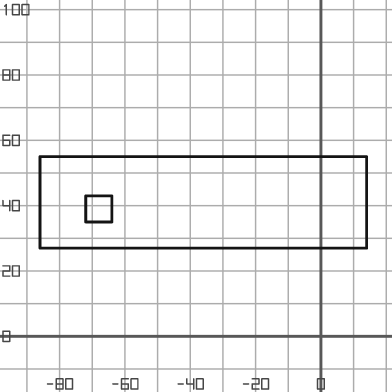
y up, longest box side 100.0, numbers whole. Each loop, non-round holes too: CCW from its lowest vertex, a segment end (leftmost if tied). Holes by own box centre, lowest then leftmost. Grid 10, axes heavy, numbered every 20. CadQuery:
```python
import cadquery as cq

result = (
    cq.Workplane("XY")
    .moveTo(-86.0, 27.0)
    .lineTo(14.0, 27.0)
    .lineTo(14.0, 55.0)
    .lineTo(-86.0, 55.0)
    .close()
    .moveTo(-72.0, 35.0)
    .lineTo(-64.0, 35.0)
    .lineTo(-64.0, 43.0)
    .lineTo(-72.0, 43.0)
    .close()
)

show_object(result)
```